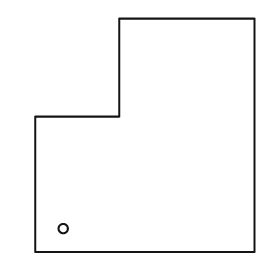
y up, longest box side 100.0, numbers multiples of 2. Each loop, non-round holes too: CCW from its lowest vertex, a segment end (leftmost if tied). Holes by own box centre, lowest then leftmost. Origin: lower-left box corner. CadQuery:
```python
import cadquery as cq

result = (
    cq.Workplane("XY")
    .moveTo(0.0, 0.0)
    .lineTo(94.0, 0.0)
    .lineTo(94.0, 100.0)
    .lineTo(36.0, 100.0)
    .lineTo(36.0, 58.0)
    .lineTo(0.0, 58.0)
    .close()
    .moveTo(12.0, 10.0)
    .circle(2.0)
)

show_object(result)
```